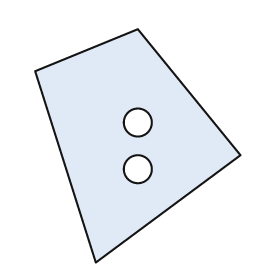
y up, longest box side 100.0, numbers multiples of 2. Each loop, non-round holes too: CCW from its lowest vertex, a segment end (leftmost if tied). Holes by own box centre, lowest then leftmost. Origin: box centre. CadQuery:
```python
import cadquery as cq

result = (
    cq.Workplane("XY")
    .moveTo(-18.0, -50.0)
    .lineTo(44.0, -4.0)
    .lineTo(0.0, 50.0)
    .lineTo(-44.0, 32.0)
    .close()
    .moveTo(0.0, -10.0)
    .circle(6.0)
    .moveTo(0.0, 10.0)
    .circle(6.0)
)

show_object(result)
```